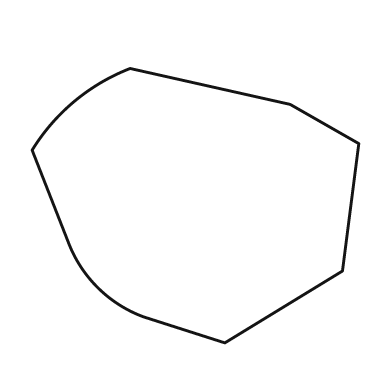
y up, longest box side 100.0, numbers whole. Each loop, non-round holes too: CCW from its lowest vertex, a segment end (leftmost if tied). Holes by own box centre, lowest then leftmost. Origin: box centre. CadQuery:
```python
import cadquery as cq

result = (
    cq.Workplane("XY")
    .moveTo(9.0, -42.0)
    .lineTo(45.0, -20.0)
    .lineTo(50.0, 19.0)
    .lineTo(29.0, 31.0)
    .lineTo(-20.0, 42.0)
    .threePointArc((-37.0, 32.0), (-50.0, 17.0))
    .lineTo(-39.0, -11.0)
    .threePointArc((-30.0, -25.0), (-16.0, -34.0))
    .close()
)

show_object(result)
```